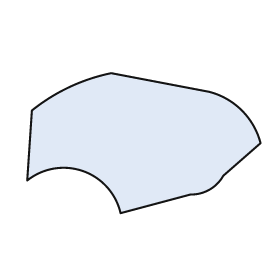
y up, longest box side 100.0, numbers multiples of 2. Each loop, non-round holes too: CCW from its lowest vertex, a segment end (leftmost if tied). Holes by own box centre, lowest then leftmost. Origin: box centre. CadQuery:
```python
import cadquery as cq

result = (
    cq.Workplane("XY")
    .moveTo(-10.0, -30.0)
    .lineTo(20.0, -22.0)
    .threePointArc((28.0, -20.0), (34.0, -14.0))
    .lineTo(50.0, 0.0)
    .threePointArc((42.0, 14.0), (28.0, 22.0))
    .lineTo(-14.0, 30.0)
    .threePointArc((-32.0, 24.0), (-48.0, 14.0))
    .lineTo(-50.0, -16.0)
    .threePointArc((-26.0, -12.0), (-10.0, -30.0))
    .close()
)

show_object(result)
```